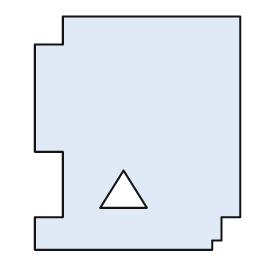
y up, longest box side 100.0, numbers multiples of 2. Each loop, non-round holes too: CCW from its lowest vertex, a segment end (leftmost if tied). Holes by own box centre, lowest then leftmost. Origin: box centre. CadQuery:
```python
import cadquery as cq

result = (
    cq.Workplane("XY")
    .moveTo(-44.0, -50.0)
    .lineTo(32.0, -50.0)
    .lineTo(32.0, -46.0)
    .lineTo(36.0, -46.0)
    .lineTo(36.0, -36.0)
    .lineTo(44.0, -36.0)
    .lineTo(44.0, 50.0)
    .lineTo(-32.0, 50.0)
    .lineTo(-32.0, 38.0)
    .lineTo(-44.0, 38.0)
    .lineTo(-44.0, -8.0)
    .lineTo(-32.0, -8.0)
    .lineTo(-32.0, -36.0)
    .lineTo(-44.0, -36.0)
    .close()
    .moveTo(-16.0, -32.0)
    .lineTo(4.0, -32.0)
    .lineTo(-6.0, -16.0)
    .close()
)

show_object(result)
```